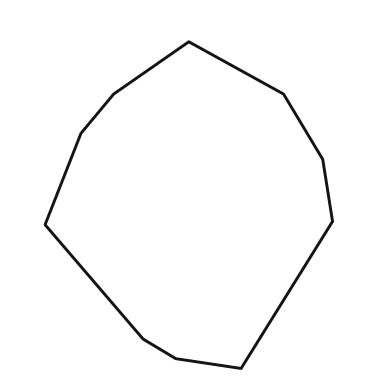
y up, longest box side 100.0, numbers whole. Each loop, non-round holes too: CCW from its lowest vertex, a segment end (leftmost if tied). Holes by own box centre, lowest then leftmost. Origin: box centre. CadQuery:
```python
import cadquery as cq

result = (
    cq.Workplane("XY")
    .moveTo(16.0, -50.0)
    .lineTo(44.0, -5.0)
    .lineTo(41.0, 14.0)
    .lineTo(29.0, 34.0)
    .lineTo(0.0, 50.0)
    .lineTo(-23.0, 34.0)
    .lineTo(-33.0, 22.0)
    .lineTo(-44.0, -6.0)
    .lineTo(-14.0, -41.0)
    .lineTo(-4.0, -47.0)
    .close()
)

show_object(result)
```